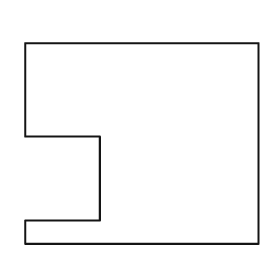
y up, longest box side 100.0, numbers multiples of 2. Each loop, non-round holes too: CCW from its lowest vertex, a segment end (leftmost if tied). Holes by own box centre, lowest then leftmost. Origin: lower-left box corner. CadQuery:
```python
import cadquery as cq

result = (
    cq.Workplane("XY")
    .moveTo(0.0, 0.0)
    .lineTo(100.0, 0.0)
    .lineTo(100.0, 86.0)
    .lineTo(0.0, 86.0)
    .lineTo(0.0, 46.0)
    .lineTo(32.0, 46.0)
    .lineTo(32.0, 10.0)
    .lineTo(0.0, 10.0)
    .close()
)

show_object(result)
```